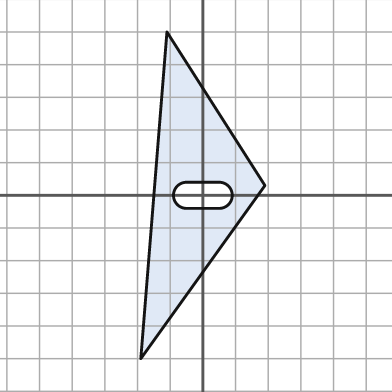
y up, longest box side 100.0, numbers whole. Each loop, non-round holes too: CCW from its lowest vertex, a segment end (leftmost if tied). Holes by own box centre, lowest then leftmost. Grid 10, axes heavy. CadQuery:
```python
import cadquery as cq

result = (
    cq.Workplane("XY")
    .moveTo(-19.0, -50.0)
    .lineTo(19.0, 3.0)
    .lineTo(-11.0, 50.0)
    .close()
    .moveTo(-5.0, -4.0)
    .lineTo(5.0, -4.0)
    .threePointArc((9.0, 0.0), (5.0, 4.0))
    .lineTo(-5.0, 4.0)
    .threePointArc((-9.0, 0.0), (-5.0, -4.0))
    .close()
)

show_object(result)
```